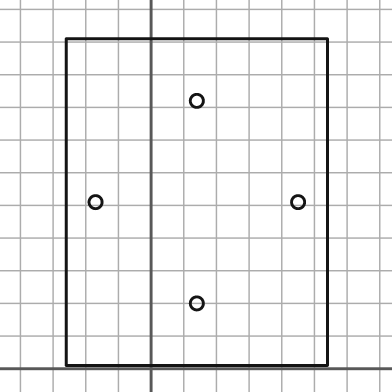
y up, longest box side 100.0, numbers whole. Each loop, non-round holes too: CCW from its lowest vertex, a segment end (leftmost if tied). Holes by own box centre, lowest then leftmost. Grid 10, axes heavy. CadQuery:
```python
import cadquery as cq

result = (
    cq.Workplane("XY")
    .moveTo(-26.0, 1.0)
    .lineTo(54.0, 1.0)
    .lineTo(54.0, 101.0)
    .lineTo(-26.0, 101.0)
    .close()
    .moveTo(14.0, 20.0)
    .circle(2.0)
    .moveTo(-17.0, 51.0)
    .circle(2.0)
    .moveTo(45.0, 51.0)
    .circle(2.0)
    .moveTo(14.0, 82.0)
    .circle(2.0)
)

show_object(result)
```